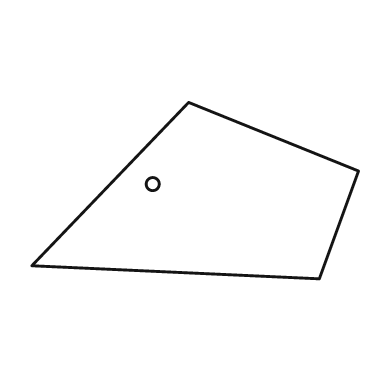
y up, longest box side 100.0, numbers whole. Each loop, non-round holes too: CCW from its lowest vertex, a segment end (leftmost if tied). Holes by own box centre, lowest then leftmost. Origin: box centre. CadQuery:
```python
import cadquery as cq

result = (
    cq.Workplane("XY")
    .moveTo(38.0, -27.0)
    .lineTo(50.0, 6.0)
    .lineTo(-2.0, 27.0)
    .lineTo(-50.0, -23.0)
    .close()
    .moveTo(-13.0, 2.0)
    .circle(2.0)
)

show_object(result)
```